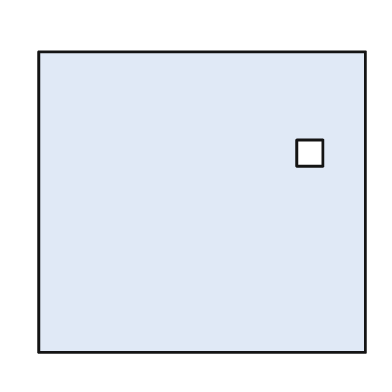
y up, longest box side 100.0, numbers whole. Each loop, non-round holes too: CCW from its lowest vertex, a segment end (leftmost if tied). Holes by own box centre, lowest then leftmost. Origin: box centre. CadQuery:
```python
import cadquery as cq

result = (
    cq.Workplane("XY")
    .moveTo(-50.0, -46.0)
    .lineTo(50.0, -46.0)
    .lineTo(50.0, 46.0)
    .lineTo(-50.0, 46.0)
    .close()
    .moveTo(29.0, 11.0)
    .lineTo(37.0, 11.0)
    .lineTo(37.0, 19.0)
    .lineTo(29.0, 19.0)
    .close()
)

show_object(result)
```